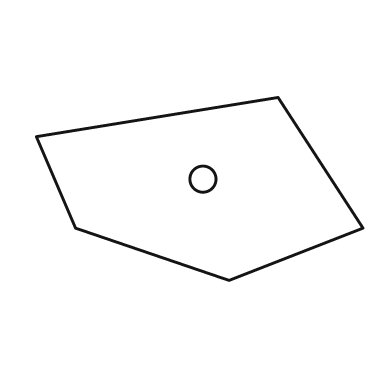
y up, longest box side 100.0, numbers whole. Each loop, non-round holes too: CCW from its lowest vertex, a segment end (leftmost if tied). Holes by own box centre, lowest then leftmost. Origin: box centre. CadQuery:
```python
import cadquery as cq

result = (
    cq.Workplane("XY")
    .moveTo(9.0, -28.0)
    .lineTo(50.0, -12.0)
    .lineTo(24.0, 28.0)
    .lineTo(-50.0, 16.0)
    .lineTo(-38.0, -12.0)
    .close()
    .moveTo(1.0, 3.0)
    .circle(4.0)
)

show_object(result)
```